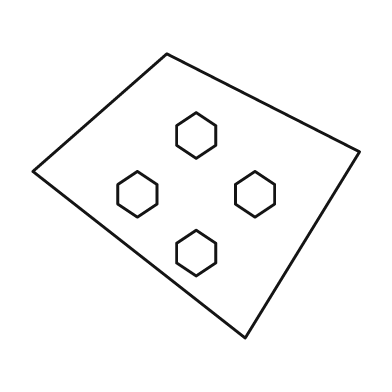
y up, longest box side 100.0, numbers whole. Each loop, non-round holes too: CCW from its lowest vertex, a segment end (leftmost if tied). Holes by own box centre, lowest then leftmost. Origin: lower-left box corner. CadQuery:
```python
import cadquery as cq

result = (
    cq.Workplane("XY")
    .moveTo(65.0, 0.0)
    .lineTo(100.0, 57.0)
    .lineTo(41.0, 87.0)
    .lineTo(0.0, 51.0)
    .close()
    .moveTo(50.0, 19.0)
    .lineTo(56.0, 23.0)
    .lineTo(56.0, 29.0)
    .lineTo(50.0, 33.0)
    .lineTo(44.0, 29.0)
    .lineTo(44.0, 23.0)
    .close()
    .moveTo(32.0, 37.0)
    .lineTo(38.0, 41.0)
    .lineTo(38.0, 47.0)
    .lineTo(32.0, 51.0)
    .lineTo(26.0, 47.0)
    .lineTo(26.0, 41.0)
    .close()
    .moveTo(68.0, 37.0)
    .lineTo(74.0, 41.0)
    .lineTo(74.0, 47.0)
    .lineTo(68.0, 51.0)
    .lineTo(62.0, 47.0)
    .lineTo(62.0, 41.0)
    .close()
    .moveTo(50.0, 55.0)
    .lineTo(56.0, 59.0)
    .lineTo(56.0, 65.0)
    .lineTo(50.0, 69.0)
    .lineTo(44.0, 65.0)
    .lineTo(44.0, 59.0)
    .close()
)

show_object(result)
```